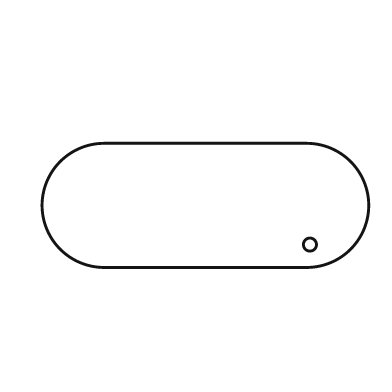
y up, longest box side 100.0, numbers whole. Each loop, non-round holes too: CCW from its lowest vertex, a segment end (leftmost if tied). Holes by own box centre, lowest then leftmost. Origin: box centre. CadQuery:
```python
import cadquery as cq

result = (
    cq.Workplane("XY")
    .moveTo(-31.0, -19.0)
    .lineTo(31.0, -19.0)
    .threePointArc((50.0, 0.0), (31.0, 19.0))
    .lineTo(-31.0, 19.0)
    .threePointArc((-50.0, 0.0), (-31.0, -19.0))
    .close()
    .moveTo(32.0, -12.0)
    .circle(2.0)
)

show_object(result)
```